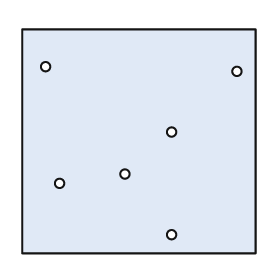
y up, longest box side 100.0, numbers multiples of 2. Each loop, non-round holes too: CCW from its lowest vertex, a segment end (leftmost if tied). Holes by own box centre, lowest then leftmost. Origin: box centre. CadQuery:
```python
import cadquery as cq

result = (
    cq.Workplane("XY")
    .moveTo(-50.0, -48.0)
    .lineTo(50.0, -48.0)
    .lineTo(50.0, 48.0)
    .lineTo(-50.0, 48.0)
    .close()
    .moveTo(14.0, -40.0)
    .circle(2.0)
    .moveTo(-34.0, -18.0)
    .circle(2.0)
    .moveTo(-6.0, -14.0)
    .circle(2.0)
    .moveTo(14.0, 4.0)
    .circle(2.0)
    .moveTo(42.0, 30.0)
    .circle(2.0)
    .moveTo(-40.0, 32.0)
    .circle(2.0)
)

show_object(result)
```